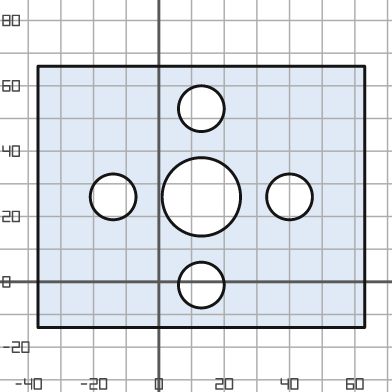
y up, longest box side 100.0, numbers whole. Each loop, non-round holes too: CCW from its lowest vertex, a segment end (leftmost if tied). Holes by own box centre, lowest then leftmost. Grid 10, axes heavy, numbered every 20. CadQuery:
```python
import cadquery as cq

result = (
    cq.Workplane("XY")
    .moveTo(-37.0, -14.0)
    .lineTo(63.0, -14.0)
    .lineTo(63.0, 66.0)
    .lineTo(-37.0, 66.0)
    .close()
    .moveTo(13.0, -1.0)
    .circle(7.0)
    .moveTo(-14.0, 26.0)
    .circle(7.0)
    .moveTo(13.0, 26.0)
    .circle(12.0)
    .moveTo(40.0, 26.0)
    .circle(7.0)
    .moveTo(13.0, 53.0)
    .circle(7.0)
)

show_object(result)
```